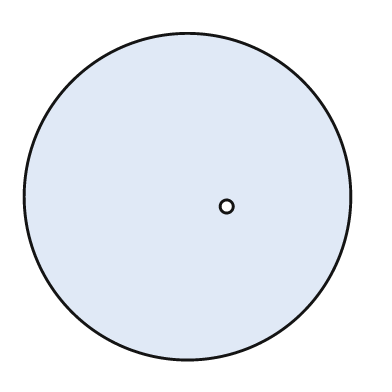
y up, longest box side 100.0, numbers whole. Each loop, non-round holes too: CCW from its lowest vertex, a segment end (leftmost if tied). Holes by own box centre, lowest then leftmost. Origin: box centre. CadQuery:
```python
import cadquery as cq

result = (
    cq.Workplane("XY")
    .moveTo(0.0, 0.0)
    .circle(50.0)
    .moveTo(12.0, -3.0)
    .circle(2.0)
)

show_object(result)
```